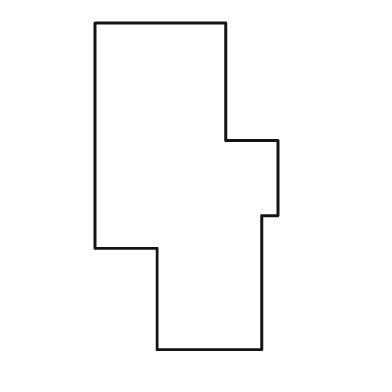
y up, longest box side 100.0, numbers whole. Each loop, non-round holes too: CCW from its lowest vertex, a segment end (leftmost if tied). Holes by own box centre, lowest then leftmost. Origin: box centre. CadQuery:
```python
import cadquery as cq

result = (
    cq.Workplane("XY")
    .moveTo(-9.0, -50.0)
    .lineTo(23.0, -50.0)
    .lineTo(23.0, -9.0)
    .lineTo(28.0, -9.0)
    .lineTo(28.0, 14.0)
    .lineTo(12.0, 14.0)
    .lineTo(12.0, 50.0)
    .lineTo(-28.0, 50.0)
    .lineTo(-28.0, -19.0)
    .lineTo(-9.0, -19.0)
    .close()
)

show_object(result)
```